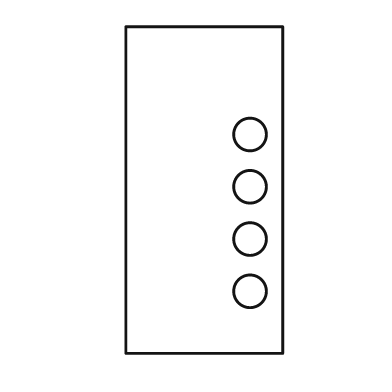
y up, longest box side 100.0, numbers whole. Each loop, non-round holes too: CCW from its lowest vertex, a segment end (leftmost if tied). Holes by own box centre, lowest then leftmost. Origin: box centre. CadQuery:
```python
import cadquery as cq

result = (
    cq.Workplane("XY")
    .moveTo(-24.0, -50.0)
    .lineTo(24.0, -50.0)
    .lineTo(24.0, 50.0)
    .lineTo(-24.0, 50.0)
    .close()
    .moveTo(14.0, -31.0)
    .circle(5.0)
    .moveTo(14.0, -15.0)
    .circle(5.0)
    .moveTo(14.0, 1.0)
    .circle(5.0)
    .moveTo(14.0, 17.0)
    .circle(5.0)
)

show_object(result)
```